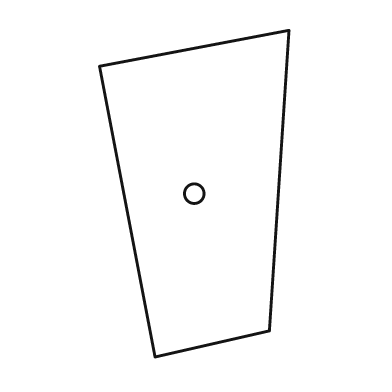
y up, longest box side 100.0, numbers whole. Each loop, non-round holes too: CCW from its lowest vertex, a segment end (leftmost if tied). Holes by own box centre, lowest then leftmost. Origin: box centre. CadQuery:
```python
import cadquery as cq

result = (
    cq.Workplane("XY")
    .moveTo(-12.0, -50.0)
    .lineTo(23.0, -42.0)
    .lineTo(29.0, 50.0)
    .lineTo(-29.0, 39.0)
    .close()
    .moveTo(0.0, 0.0)
    .circle(3.0)
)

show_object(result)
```